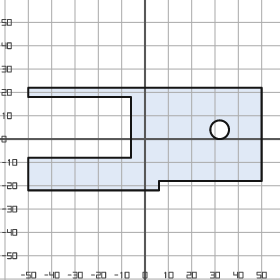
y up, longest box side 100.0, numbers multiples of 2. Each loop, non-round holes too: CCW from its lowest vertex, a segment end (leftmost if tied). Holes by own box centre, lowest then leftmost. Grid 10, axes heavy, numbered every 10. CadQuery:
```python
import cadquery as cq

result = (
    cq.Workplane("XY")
    .moveTo(-50.0, -22.0)
    .lineTo(6.0, -22.0)
    .lineTo(6.0, -18.0)
    .lineTo(50.0, -18.0)
    .lineTo(50.0, 22.0)
    .lineTo(-50.0, 22.0)
    .lineTo(-50.0, 18.0)
    .lineTo(-6.0, 18.0)
    .lineTo(-6.0, -8.0)
    .lineTo(-50.0, -8.0)
    .close()
    .moveTo(32.0, 4.0)
    .circle(4.0)
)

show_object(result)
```